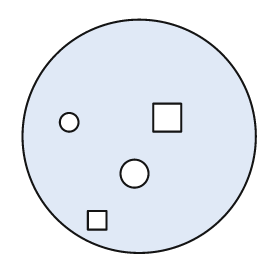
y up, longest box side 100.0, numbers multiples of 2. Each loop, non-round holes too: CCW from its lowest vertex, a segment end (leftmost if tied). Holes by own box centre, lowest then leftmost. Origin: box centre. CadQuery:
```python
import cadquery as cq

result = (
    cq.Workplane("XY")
    .moveTo(0.0, 0.0)
    .circle(50.0)
    .moveTo(-22.0, -40.0)
    .lineTo(-14.0, -40.0)
    .lineTo(-14.0, -32.0)
    .lineTo(-22.0, -32.0)
    .close()
    .moveTo(-2.0, -16.0)
    .circle(6.0)
    .moveTo(-30.0, 6.0)
    .circle(4.0)
    .moveTo(6.0, 2.0)
    .lineTo(18.0, 2.0)
    .lineTo(18.0, 14.0)
    .lineTo(6.0, 14.0)
    .close()
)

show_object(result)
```